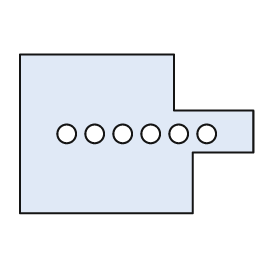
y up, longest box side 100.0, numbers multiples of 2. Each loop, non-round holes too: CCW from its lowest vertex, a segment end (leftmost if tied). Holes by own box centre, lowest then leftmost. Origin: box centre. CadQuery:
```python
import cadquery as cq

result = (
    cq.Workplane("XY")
    .moveTo(-50.0, -34.0)
    .lineTo(24.0, -34.0)
    .lineTo(24.0, -8.0)
    .lineTo(50.0, -8.0)
    .lineTo(50.0, 10.0)
    .lineTo(16.0, 10.0)
    .lineTo(16.0, 34.0)
    .lineTo(-50.0, 34.0)
    .close()
    .moveTo(-30.0, 0.0)
    .circle(4.0)
    .moveTo(-18.0, 0.0)
    .circle(4.0)
    .moveTo(-6.0, 0.0)
    .circle(4.0)
    .moveTo(6.0, 0.0)
    .circle(4.0)
    .moveTo(18.0, 0.0)
    .circle(4.0)
    .moveTo(30.0, 0.0)
    .circle(4.0)
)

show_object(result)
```